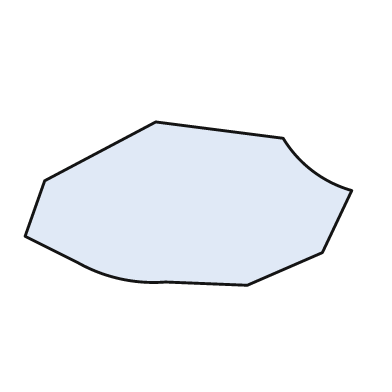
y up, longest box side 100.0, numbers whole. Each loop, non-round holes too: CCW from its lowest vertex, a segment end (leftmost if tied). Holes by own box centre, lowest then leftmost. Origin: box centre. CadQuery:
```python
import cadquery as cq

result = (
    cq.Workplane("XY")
    .moveTo(18.0, -25.0)
    .lineTo(41.0, -15.0)
    .lineTo(50.0, 4.0)
    .threePointArc((38.0, 10.0), (29.0, 20.0))
    .lineTo(-10.0, 25.0)
    .lineTo(-44.0, 7.0)
    .lineTo(-50.0, -10.0)
    .lineTo(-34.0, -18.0)
    .threePointArc((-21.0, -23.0), (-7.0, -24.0))
    .close()
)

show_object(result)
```